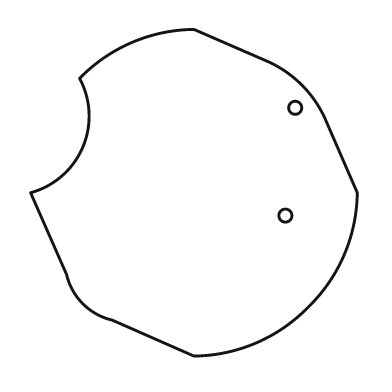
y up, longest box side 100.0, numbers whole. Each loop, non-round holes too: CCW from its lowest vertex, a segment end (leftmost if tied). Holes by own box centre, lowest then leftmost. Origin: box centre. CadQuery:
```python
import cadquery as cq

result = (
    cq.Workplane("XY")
    .moveTo(0.0, -50.0)
    .threePointArc((19.0, -46.0), (35.0, -35.0))
    .threePointArc((46.0, -19.0), (50.0, 0.0))
    .lineTo(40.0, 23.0)
    .threePointArc((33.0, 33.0), (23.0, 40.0))
    .lineTo(0.0, 50.0)
    .threePointArc((-19.0, 46.0), (-35.0, 35.0))
    .threePointArc((-34.0, 14.0), (-50.0, 0.0))
    .lineTo(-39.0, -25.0)
    .threePointArc((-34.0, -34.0), (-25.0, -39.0))
    .close()
    .moveTo(28.0, -7.0)
    .circle(2.0)
    .moveTo(31.0, 26.0)
    .circle(2.0)
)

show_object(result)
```